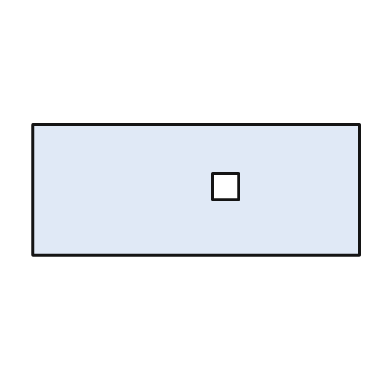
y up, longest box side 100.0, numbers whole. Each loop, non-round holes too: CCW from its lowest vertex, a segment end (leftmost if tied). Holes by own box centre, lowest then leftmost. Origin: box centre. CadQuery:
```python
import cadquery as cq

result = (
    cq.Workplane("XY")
    .moveTo(-50.0, -20.0)
    .lineTo(50.0, -20.0)
    .lineTo(50.0, 20.0)
    .lineTo(-50.0, 20.0)
    .close()
    .moveTo(5.0, -3.0)
    .lineTo(13.0, -3.0)
    .lineTo(13.0, 5.0)
    .lineTo(5.0, 5.0)
    .close()
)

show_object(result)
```